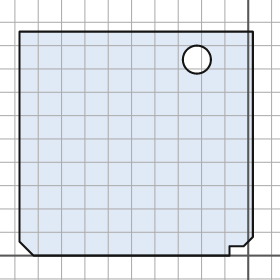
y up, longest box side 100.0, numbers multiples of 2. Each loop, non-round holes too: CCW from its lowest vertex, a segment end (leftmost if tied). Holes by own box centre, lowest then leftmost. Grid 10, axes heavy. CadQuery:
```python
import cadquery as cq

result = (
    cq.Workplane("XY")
    .moveTo(-92.0, 0.0)
    .lineTo(-8.0, 0.0)
    .lineTo(-8.0, 4.0)
    .lineTo(-2.0, 4.0)
    .lineTo(2.0, 8.0)
    .lineTo(2.0, 96.0)
    .lineTo(-98.0, 96.0)
    .lineTo(-98.0, 6.0)
    .close()
    .moveTo(-22.0, 84.0)
    .circle(6.0)
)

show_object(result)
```